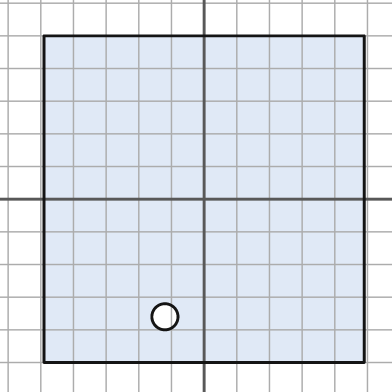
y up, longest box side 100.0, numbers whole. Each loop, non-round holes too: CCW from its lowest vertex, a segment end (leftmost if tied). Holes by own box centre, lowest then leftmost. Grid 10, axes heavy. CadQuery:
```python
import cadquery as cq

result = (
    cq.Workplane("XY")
    .moveTo(-49.0, -50.0)
    .lineTo(49.0, -50.0)
    .lineTo(49.0, 50.0)
    .lineTo(-49.0, 50.0)
    .close()
    .moveTo(-12.0, -36.0)
    .circle(4.0)
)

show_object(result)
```